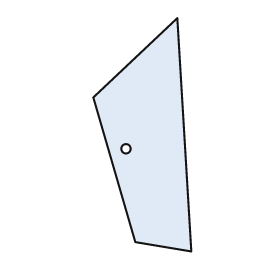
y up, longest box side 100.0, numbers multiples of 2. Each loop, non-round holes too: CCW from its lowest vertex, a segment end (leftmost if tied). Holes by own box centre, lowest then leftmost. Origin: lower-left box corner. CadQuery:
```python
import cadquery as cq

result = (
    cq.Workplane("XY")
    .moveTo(42.0, 0.0)
    .lineTo(36.0, 100.0)
    .lineTo(0.0, 66.0)
    .lineTo(18.0, 4.0)
    .close()
    .moveTo(14.0, 44.0)
    .circle(2.0)
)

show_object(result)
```